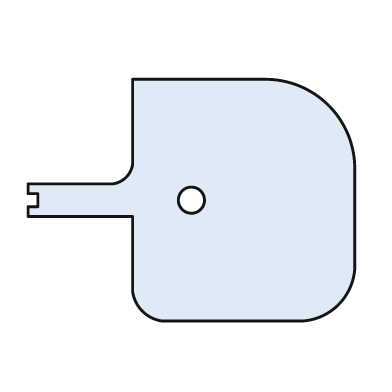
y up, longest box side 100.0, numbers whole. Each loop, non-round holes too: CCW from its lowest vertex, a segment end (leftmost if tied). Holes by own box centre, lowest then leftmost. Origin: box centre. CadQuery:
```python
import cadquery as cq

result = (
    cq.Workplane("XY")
    .moveTo(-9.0, -37.0)
    .lineTo(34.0, -37.0)
    .threePointArc((45.0, -32.0), (50.0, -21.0))
    .lineTo(50.0, 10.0)
    .threePointArc((42.0, 29.0), (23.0, 37.0))
    .lineTo(-18.0, 37.0)
    .lineTo(-18.0, 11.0)
    .threePointArc((-20.0, 7.0), (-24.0, 5.0))
    .lineTo(-50.0, 5.0)
    .lineTo(-50.0, 2.0)
    .lineTo(-47.0, 2.0)
    .lineTo(-47.0, -2.0)
    .lineTo(-50.0, -2.0)
    .lineTo(-50.0, -5.0)
    .lineTo(-18.0, -5.0)
    .lineTo(-18.0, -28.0)
    .threePointArc((-15.0, -34.0), (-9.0, -37.0))
    .close()
    .moveTo(0.0, 0.0)
    .circle(4.0)
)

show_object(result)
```